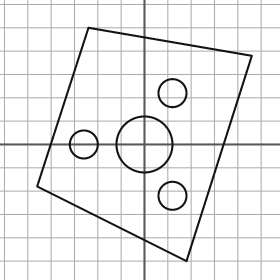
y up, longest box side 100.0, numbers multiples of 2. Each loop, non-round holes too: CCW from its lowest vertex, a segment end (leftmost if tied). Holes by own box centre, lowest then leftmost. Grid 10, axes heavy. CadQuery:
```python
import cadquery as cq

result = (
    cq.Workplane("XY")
    .moveTo(18.0, -50.0)
    .lineTo(46.0, 38.0)
    .lineTo(-24.0, 50.0)
    .lineTo(-46.0, -18.0)
    .close()
    .moveTo(12.0, -22.0)
    .circle(6.0)
    .moveTo(-26.0, 0.0)
    .circle(6.0)
    .moveTo(0.0, 0.0)
    .circle(12.0)
    .moveTo(12.0, 22.0)
    .circle(6.0)
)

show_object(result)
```